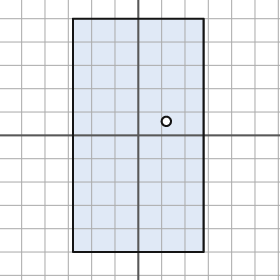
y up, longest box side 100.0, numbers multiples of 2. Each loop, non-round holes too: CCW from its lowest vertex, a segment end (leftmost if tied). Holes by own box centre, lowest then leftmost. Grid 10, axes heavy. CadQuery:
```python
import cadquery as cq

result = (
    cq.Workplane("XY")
    .moveTo(-28.0, -50.0)
    .lineTo(28.0, -50.0)
    .lineTo(28.0, 50.0)
    .lineTo(-28.0, 50.0)
    .close()
    .moveTo(12.0, 6.0)
    .circle(2.0)
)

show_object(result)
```